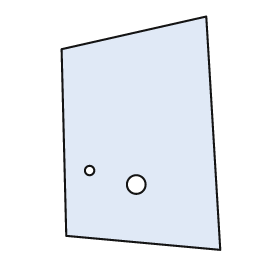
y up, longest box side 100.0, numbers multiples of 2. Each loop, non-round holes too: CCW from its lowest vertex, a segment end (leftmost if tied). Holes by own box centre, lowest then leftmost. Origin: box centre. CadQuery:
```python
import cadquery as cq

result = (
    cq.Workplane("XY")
    .moveTo(34.0, -50.0)
    .lineTo(28.0, 50.0)
    .lineTo(-34.0, 36.0)
    .lineTo(-32.0, -44.0)
    .close()
    .moveTo(-2.0, -22.0)
    .circle(4.0)
    .moveTo(-22.0, -16.0)
    .circle(2.0)
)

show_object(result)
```